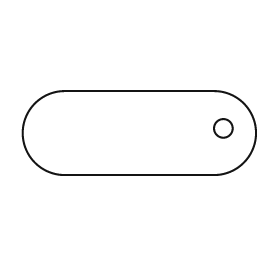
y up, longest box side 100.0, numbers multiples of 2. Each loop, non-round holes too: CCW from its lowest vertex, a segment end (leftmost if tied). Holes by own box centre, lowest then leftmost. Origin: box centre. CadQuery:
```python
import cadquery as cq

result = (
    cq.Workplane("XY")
    .moveTo(-32.0, -18.0)
    .lineTo(32.0, -18.0)
    .threePointArc((50.0, 0.0), (32.0, 18.0))
    .lineTo(-32.0, 18.0)
    .threePointArc((-50.0, 0.0), (-32.0, -18.0))
    .close()
    .moveTo(36.0, 2.0)
    .circle(4.0)
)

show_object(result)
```